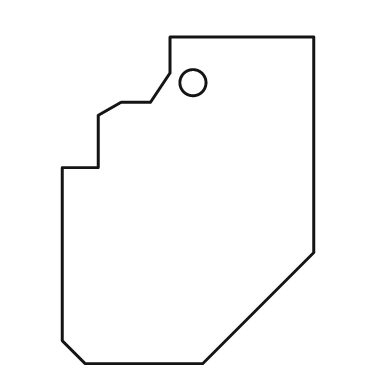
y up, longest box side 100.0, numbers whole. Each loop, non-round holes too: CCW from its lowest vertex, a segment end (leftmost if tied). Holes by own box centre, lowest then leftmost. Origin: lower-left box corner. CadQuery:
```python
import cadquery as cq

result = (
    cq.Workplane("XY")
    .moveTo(7.0, 0.0)
    .lineTo(43.0, 0.0)
    .lineTo(77.0, 34.0)
    .lineTo(77.0, 100.0)
    .lineTo(33.0, 100.0)
    .lineTo(33.0, 89.0)
    .lineTo(27.0, 80.0)
    .lineTo(18.0, 80.0)
    .lineTo(11.0, 76.0)
    .lineTo(11.0, 60.0)
    .lineTo(0.0, 60.0)
    .lineTo(0.0, 7.0)
    .close()
    .moveTo(40.0, 86.0)
    .circle(4.0)
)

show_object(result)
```